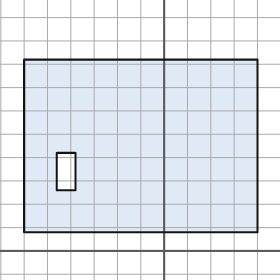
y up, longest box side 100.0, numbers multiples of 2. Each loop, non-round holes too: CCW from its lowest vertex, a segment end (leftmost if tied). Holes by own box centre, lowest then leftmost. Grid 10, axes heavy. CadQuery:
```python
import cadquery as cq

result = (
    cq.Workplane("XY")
    .moveTo(-60.0, 8.0)
    .lineTo(40.0, 8.0)
    .lineTo(40.0, 82.0)
    .lineTo(-60.0, 82.0)
    .close()
    .moveTo(-46.0, 26.0)
    .lineTo(-38.0, 26.0)
    .lineTo(-38.0, 42.0)
    .lineTo(-46.0, 42.0)
    .close()
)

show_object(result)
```